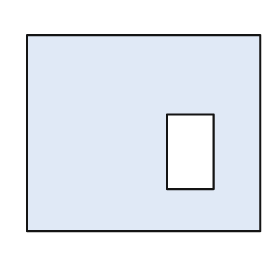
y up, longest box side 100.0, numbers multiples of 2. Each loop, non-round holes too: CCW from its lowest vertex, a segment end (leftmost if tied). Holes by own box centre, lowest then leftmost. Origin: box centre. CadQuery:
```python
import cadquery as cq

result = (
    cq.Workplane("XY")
    .moveTo(-50.0, -42.0)
    .lineTo(50.0, -42.0)
    .lineTo(50.0, 42.0)
    .lineTo(-50.0, 42.0)
    .close()
    .moveTo(10.0, -24.0)
    .lineTo(30.0, -24.0)
    .lineTo(30.0, 8.0)
    .lineTo(10.0, 8.0)
    .close()
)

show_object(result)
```